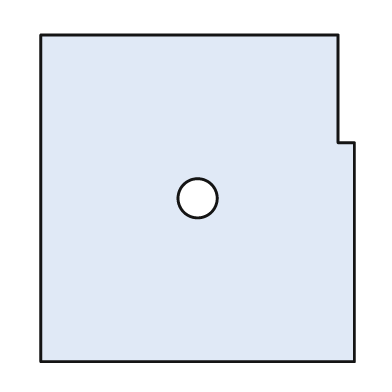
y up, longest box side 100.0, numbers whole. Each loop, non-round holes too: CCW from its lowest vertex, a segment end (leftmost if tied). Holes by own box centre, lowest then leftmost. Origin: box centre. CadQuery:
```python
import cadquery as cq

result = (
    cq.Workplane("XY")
    .moveTo(-48.0, -50.0)
    .lineTo(48.0, -50.0)
    .lineTo(48.0, 17.0)
    .lineTo(43.0, 17.0)
    .lineTo(43.0, 50.0)
    .lineTo(-48.0, 50.0)
    .close()
    .moveTo(0.0, 0.0)
    .circle(6.0)
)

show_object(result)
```